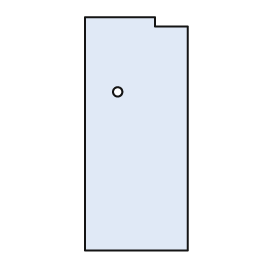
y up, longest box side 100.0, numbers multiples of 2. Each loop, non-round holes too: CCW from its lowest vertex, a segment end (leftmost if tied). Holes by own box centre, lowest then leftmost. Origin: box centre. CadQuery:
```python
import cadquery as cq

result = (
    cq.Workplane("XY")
    .moveTo(-22.0, -50.0)
    .lineTo(22.0, -50.0)
    .lineTo(22.0, 46.0)
    .lineTo(8.0, 46.0)
    .lineTo(8.0, 50.0)
    .lineTo(-22.0, 50.0)
    .close()
    .moveTo(-8.0, 18.0)
    .circle(2.0)
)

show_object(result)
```